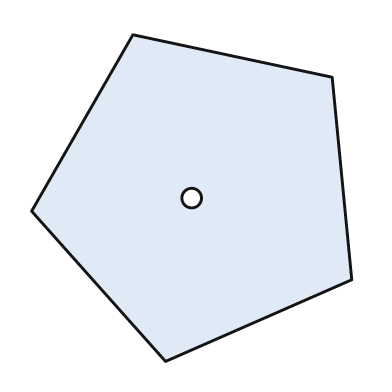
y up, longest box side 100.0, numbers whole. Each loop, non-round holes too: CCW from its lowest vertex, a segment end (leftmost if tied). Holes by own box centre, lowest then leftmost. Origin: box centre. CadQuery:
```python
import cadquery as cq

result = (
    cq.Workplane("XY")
    .moveTo(-8.0, -50.0)
    .lineTo(49.0, -25.0)
    .lineTo(43.0, 37.0)
    .lineTo(-18.0, 50.0)
    .lineTo(-49.0, -4.0)
    .close()
    .moveTo(0.0, 0.0)
    .circle(3.0)
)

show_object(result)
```